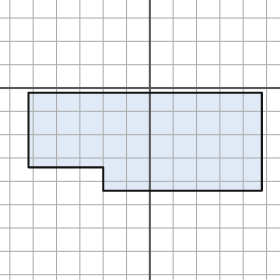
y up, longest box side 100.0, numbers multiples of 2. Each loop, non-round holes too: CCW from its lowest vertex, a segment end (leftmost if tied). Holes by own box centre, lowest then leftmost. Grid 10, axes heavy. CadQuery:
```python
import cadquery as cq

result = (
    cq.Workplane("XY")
    .moveTo(-20.0, -44.0)
    .lineTo(48.0, -44.0)
    .lineTo(48.0, -2.0)
    .lineTo(-52.0, -2.0)
    .lineTo(-52.0, -34.0)
    .lineTo(-20.0, -34.0)
    .close()
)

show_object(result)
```